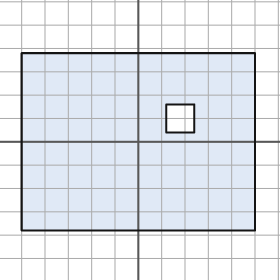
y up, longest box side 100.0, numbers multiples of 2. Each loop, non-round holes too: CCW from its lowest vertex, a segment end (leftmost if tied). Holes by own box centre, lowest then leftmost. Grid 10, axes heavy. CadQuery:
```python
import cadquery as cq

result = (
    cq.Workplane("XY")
    .moveTo(-50.0, -38.0)
    .lineTo(50.0, -38.0)
    .lineTo(50.0, 38.0)
    .lineTo(-50.0, 38.0)
    .close()
    .moveTo(12.0, 4.0)
    .lineTo(24.0, 4.0)
    .lineTo(24.0, 16.0)
    .lineTo(12.0, 16.0)
    .close()
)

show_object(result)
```